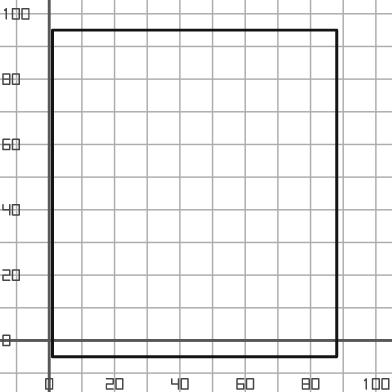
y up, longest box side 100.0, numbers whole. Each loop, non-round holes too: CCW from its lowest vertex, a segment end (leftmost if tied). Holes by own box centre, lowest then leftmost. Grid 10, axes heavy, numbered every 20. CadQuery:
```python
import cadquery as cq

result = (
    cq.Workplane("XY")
    .moveTo(1.0, -5.0)
    .lineTo(88.0, -5.0)
    .lineTo(88.0, 95.0)
    .lineTo(1.0, 95.0)
    .close()
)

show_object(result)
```